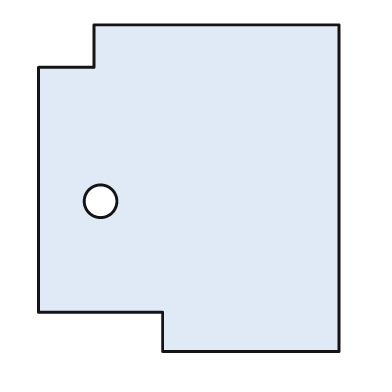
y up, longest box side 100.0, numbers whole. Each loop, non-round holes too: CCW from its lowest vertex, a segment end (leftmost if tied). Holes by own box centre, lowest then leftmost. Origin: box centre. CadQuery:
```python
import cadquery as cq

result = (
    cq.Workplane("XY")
    .moveTo(-8.0, -50.0)
    .lineTo(46.0, -50.0)
    .lineTo(46.0, 50.0)
    .lineTo(-29.0, 50.0)
    .lineTo(-29.0, 37.0)
    .lineTo(-46.0, 37.0)
    .lineTo(-46.0, -38.0)
    .lineTo(-8.0, -38.0)
    .close()
    .moveTo(-27.0, -4.0)
    .circle(5.0)
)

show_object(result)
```